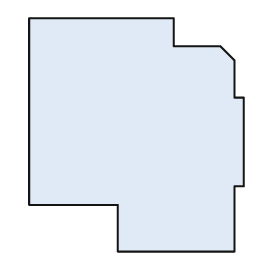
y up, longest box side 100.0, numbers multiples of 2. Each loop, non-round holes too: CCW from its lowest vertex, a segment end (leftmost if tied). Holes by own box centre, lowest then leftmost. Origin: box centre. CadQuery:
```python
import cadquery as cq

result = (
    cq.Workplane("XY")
    .moveTo(-8.0, -50.0)
    .lineTo(42.0, -50.0)
    .lineTo(42.0, -22.0)
    .lineTo(46.0, -22.0)
    .lineTo(46.0, 16.0)
    .lineTo(42.0, 16.0)
    .lineTo(42.0, 32.0)
    .lineTo(36.0, 38.0)
    .lineTo(16.0, 38.0)
    .lineTo(16.0, 50.0)
    .lineTo(-46.0, 50.0)
    .lineTo(-46.0, -30.0)
    .lineTo(-8.0, -30.0)
    .close()
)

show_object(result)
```